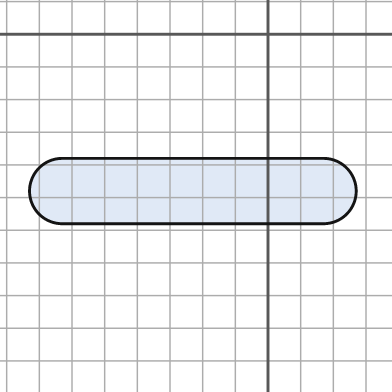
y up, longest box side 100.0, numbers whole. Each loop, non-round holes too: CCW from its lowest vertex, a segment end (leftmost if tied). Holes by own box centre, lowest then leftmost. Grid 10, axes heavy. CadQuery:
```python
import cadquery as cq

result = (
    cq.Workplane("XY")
    .moveTo(-63.0, -58.0)
    .lineTo(17.0, -58.0)
    .threePointArc((27.0, -48.0), (17.0, -38.0))
    .lineTo(-63.0, -38.0)
    .threePointArc((-73.0, -48.0), (-63.0, -58.0))
    .close()
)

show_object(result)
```